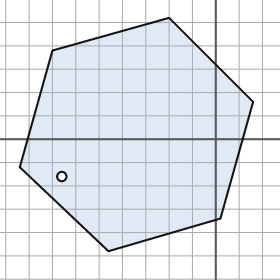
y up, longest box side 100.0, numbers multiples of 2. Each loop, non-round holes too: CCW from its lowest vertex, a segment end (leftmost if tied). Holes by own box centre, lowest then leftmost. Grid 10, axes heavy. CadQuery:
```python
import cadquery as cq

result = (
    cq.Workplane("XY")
    .moveTo(-46.0, -48.0)
    .lineTo(2.0, -34.0)
    .lineTo(16.0, 16.0)
    .lineTo(-20.0, 52.0)
    .lineTo(-70.0, 38.0)
    .lineTo(-84.0, -12.0)
    .close()
    .moveTo(-66.0, -16.0)
    .circle(2.0)
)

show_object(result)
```